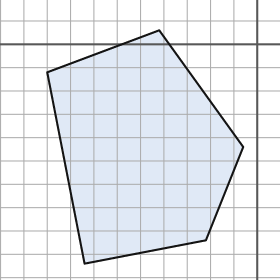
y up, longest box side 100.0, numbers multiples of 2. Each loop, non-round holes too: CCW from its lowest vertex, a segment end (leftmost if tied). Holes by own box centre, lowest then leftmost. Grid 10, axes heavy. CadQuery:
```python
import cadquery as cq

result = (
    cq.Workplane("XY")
    .moveTo(-74.0, -94.0)
    .lineTo(-22.0, -84.0)
    .lineTo(-6.0, -44.0)
    .lineTo(-42.0, 6.0)
    .lineTo(-90.0, -12.0)
    .close()
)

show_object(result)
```